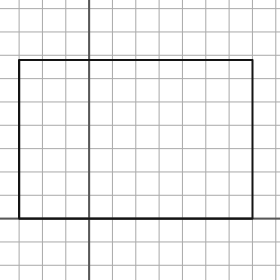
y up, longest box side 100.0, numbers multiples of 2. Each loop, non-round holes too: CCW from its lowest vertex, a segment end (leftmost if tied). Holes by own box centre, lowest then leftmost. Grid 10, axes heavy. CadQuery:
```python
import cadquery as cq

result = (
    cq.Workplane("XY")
    .moveTo(-30.0, 0.0)
    .lineTo(70.0, 0.0)
    .lineTo(70.0, 68.0)
    .lineTo(-30.0, 68.0)
    .close()
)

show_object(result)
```